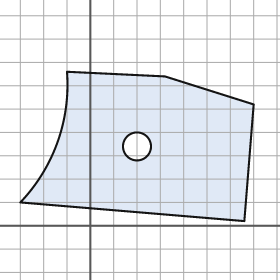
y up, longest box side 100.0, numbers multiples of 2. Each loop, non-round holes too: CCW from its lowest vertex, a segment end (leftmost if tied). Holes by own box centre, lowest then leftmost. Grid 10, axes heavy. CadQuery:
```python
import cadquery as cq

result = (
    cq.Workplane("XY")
    .moveTo(66.0, 2.0)
    .lineTo(70.0, 52.0)
    .lineTo(32.0, 64.0)
    .lineTo(-10.0, 66.0)
    .threePointArc((-14.0, 36.0), (-30.0, 10.0))
    .close()
    .moveTo(20.0, 34.0)
    .circle(6.0)
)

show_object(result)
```